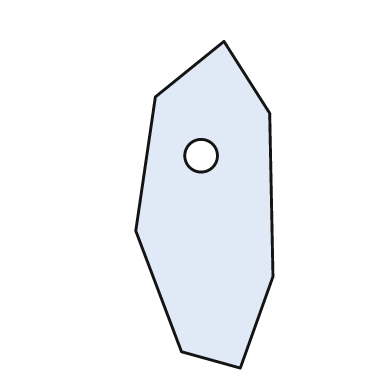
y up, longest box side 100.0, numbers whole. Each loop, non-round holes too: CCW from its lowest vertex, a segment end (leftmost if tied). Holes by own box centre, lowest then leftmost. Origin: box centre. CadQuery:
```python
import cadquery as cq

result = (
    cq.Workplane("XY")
    .moveTo(11.0, -50.0)
    .lineTo(21.0, -22.0)
    .lineTo(20.0, 28.0)
    .lineTo(6.0, 50.0)
    .lineTo(-15.0, 33.0)
    .lineTo(-21.0, -8.0)
    .lineTo(-7.0, -45.0)
    .close()
    .moveTo(-1.0, 15.0)
    .circle(5.0)
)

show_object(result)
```